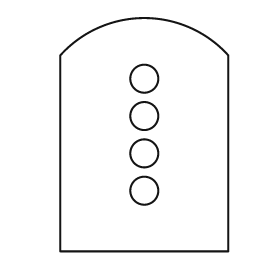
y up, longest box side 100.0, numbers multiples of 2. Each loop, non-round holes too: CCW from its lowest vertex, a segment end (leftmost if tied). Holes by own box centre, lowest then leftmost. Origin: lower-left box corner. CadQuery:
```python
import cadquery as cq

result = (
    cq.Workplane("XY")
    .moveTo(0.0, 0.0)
    .lineTo(72.0, 0.0)
    .lineTo(72.0, 84.0)
    .threePointArc((36.0, 100.0), (0.0, 84.0))
    .close()
    .moveTo(36.0, 26.0)
    .circle(6.0)
    .moveTo(36.0, 42.0)
    .circle(6.0)
    .moveTo(36.0, 58.0)
    .circle(6.0)
    .moveTo(36.0, 74.0)
    .circle(6.0)
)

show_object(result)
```